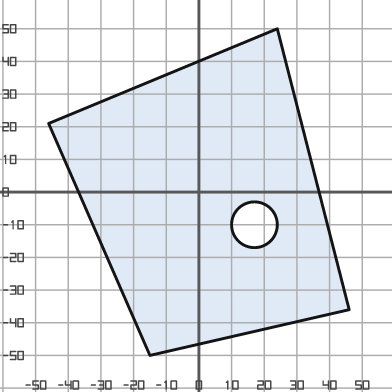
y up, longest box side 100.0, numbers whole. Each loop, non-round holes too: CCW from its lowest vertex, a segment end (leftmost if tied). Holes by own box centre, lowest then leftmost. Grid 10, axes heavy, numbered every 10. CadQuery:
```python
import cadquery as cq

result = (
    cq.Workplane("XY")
    .moveTo(-15.0, -50.0)
    .lineTo(46.0, -36.0)
    .lineTo(24.0, 50.0)
    .lineTo(-46.0, 21.0)
    .close()
    .moveTo(17.0, -10.0)
    .circle(7.0)
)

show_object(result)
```